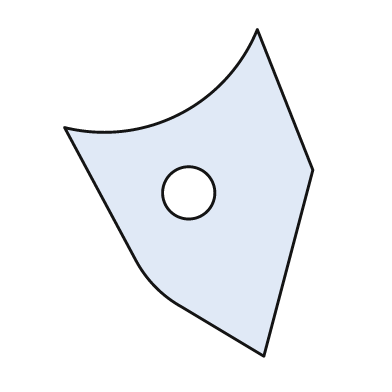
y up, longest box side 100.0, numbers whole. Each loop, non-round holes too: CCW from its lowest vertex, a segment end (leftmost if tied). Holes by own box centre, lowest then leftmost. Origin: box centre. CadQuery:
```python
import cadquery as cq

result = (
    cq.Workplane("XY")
    .moveTo(23.0, -50.0)
    .lineTo(38.0, 7.0)
    .lineTo(21.0, 50.0)
    .threePointArc((-3.0, 24.0), (-38.0, 20.0))
    .lineTo(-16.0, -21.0)
    .threePointArc((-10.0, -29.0), (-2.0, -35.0))
    .close()
    .moveTo(0.0, 0.0)
    .circle(8.0)
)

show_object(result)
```